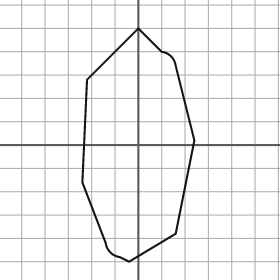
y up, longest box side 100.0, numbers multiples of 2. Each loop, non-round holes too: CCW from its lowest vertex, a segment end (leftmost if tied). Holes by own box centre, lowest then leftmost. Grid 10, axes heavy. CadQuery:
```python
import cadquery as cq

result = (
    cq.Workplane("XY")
    .moveTo(-4.0, -50.0)
    .lineTo(16.0, -38.0)
    .lineTo(24.0, 2.0)
    .lineTo(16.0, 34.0)
    .threePointArc((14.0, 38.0), (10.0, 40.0))
    .lineTo(0.0, 50.0)
    .lineTo(-22.0, 28.0)
    .lineTo(-24.0, -16.0)
    .lineTo(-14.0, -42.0)
    .threePointArc((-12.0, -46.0), (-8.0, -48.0))
    .close()
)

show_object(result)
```